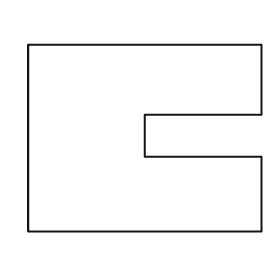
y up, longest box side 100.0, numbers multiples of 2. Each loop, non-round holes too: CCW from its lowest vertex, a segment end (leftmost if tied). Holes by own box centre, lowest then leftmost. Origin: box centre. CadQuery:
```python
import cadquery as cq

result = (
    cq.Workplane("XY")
    .moveTo(-50.0, -40.0)
    .lineTo(50.0, -40.0)
    .lineTo(50.0, -8.0)
    .lineTo(0.0, -8.0)
    .lineTo(0.0, 10.0)
    .lineTo(50.0, 10.0)
    .lineTo(50.0, 40.0)
    .lineTo(-50.0, 40.0)
    .close()
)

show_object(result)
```